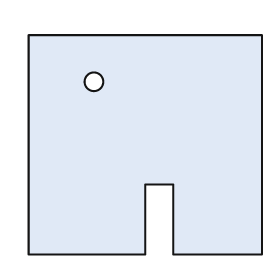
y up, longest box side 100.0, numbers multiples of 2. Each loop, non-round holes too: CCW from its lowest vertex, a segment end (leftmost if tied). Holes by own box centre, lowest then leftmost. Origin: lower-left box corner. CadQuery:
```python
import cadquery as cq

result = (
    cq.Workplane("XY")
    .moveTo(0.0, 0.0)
    .lineTo(50.0, 0.0)
    .lineTo(50.0, 30.0)
    .lineTo(62.0, 30.0)
    .lineTo(62.0, 0.0)
    .lineTo(100.0, 0.0)
    .lineTo(100.0, 94.0)
    .lineTo(0.0, 94.0)
    .close()
    .moveTo(28.0, 74.0)
    .circle(4.0)
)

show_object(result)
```